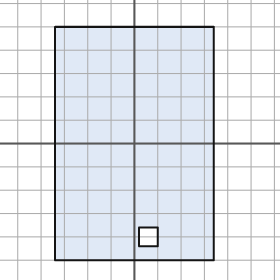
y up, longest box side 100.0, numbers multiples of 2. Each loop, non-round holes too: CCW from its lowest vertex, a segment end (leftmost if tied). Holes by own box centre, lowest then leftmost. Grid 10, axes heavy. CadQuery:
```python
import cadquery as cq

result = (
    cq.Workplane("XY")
    .moveTo(-34.0, -50.0)
    .lineTo(34.0, -50.0)
    .lineTo(34.0, 50.0)
    .lineTo(-34.0, 50.0)
    .close()
    .moveTo(2.0, -44.0)
    .lineTo(10.0, -44.0)
    .lineTo(10.0, -36.0)
    .lineTo(2.0, -36.0)
    .close()
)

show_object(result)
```